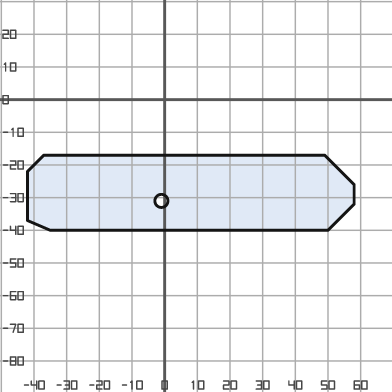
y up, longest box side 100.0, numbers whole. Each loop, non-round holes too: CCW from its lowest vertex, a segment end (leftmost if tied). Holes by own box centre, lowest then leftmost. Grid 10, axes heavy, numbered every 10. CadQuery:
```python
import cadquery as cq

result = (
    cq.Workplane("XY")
    .moveTo(-35.0, -40.0)
    .lineTo(50.0, -40.0)
    .lineTo(58.0, -32.0)
    .lineTo(58.0, -26.0)
    .lineTo(49.0, -17.0)
    .lineTo(-37.0, -17.0)
    .lineTo(-42.0, -22.0)
    .lineTo(-42.0, -37.0)
    .close()
    .moveTo(-1.0, -31.0)
    .circle(2.0)
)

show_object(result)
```